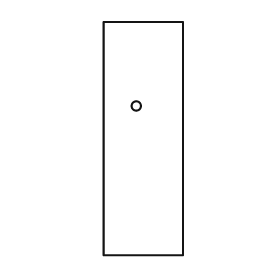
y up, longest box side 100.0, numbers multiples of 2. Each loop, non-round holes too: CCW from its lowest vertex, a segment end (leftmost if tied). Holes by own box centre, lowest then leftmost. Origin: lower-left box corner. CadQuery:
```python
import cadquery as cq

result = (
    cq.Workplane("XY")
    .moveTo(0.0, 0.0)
    .lineTo(34.0, 0.0)
    .lineTo(34.0, 100.0)
    .lineTo(0.0, 100.0)
    .close()
    .moveTo(14.0, 64.0)
    .circle(2.0)
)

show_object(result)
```